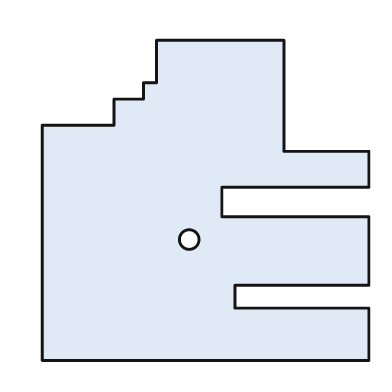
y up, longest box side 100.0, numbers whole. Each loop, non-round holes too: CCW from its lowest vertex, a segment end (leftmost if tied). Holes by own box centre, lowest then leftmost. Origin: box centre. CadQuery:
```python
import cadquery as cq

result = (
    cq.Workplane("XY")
    .moveTo(-50.0, -49.0)
    .lineTo(50.0, -49.0)
    .lineTo(50.0, -33.0)
    .lineTo(9.0, -33.0)
    .lineTo(9.0, -26.0)
    .lineTo(50.0, -26.0)
    .lineTo(50.0, -5.0)
    .lineTo(5.0, -5.0)
    .lineTo(5.0, 4.0)
    .lineTo(50.0, 4.0)
    .lineTo(50.0, 15.0)
    .lineTo(24.0, 15.0)
    .lineTo(24.0, 49.0)
    .lineTo(-15.0, 49.0)
    .lineTo(-15.0, 36.0)
    .lineTo(-19.0, 36.0)
    .lineTo(-19.0, 31.0)
    .lineTo(-28.0, 31.0)
    .lineTo(-28.0, 23.0)
    .lineTo(-50.0, 23.0)
    .close()
    .moveTo(-5.0, -12.0)
    .circle(3.0)
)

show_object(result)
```